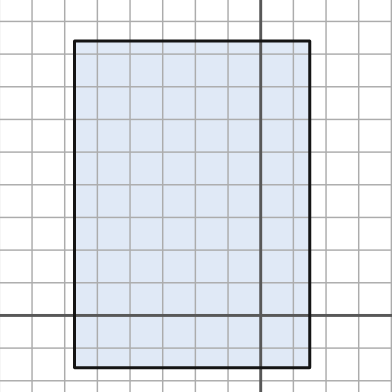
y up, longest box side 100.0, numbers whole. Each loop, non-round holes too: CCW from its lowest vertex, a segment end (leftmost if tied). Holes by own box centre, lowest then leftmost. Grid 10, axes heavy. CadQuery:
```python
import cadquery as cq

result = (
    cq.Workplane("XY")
    .moveTo(-57.0, -16.0)
    .lineTo(15.0, -16.0)
    .lineTo(15.0, 84.0)
    .lineTo(-57.0, 84.0)
    .close()
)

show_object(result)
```